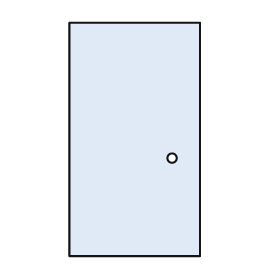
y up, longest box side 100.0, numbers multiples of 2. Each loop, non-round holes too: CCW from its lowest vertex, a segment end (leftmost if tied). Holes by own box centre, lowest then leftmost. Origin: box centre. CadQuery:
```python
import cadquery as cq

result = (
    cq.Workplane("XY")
    .moveTo(-28.0, -50.0)
    .lineTo(28.0, -50.0)
    .lineTo(28.0, 50.0)
    .lineTo(-28.0, 50.0)
    .close()
    .moveTo(16.0, -8.0)
    .circle(2.0)
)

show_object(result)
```